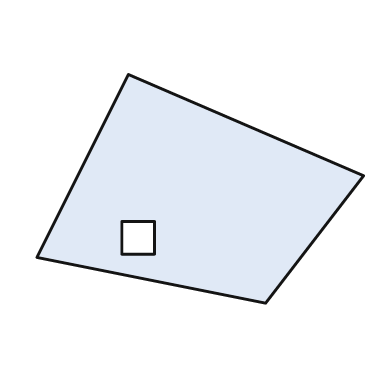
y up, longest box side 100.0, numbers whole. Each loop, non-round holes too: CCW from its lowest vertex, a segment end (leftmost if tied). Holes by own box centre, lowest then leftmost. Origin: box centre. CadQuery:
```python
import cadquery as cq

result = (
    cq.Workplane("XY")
    .moveTo(20.0, -35.0)
    .lineTo(50.0, 4.0)
    .lineTo(-22.0, 35.0)
    .lineTo(-50.0, -21.0)
    .close()
    .moveTo(-24.0, -20.0)
    .lineTo(-14.0, -20.0)
    .lineTo(-14.0, -10.0)
    .lineTo(-24.0, -10.0)
    .close()
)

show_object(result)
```